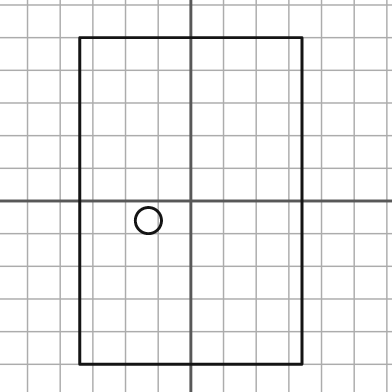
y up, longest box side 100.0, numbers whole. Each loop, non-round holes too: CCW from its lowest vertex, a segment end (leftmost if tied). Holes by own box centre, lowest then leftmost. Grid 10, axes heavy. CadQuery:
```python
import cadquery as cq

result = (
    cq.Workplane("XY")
    .moveTo(-34.0, -50.0)
    .lineTo(34.0, -50.0)
    .lineTo(34.0, 50.0)
    .lineTo(-34.0, 50.0)
    .close()
    .moveTo(-13.0, -6.0)
    .circle(4.0)
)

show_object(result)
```